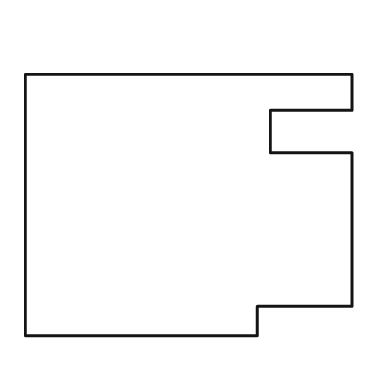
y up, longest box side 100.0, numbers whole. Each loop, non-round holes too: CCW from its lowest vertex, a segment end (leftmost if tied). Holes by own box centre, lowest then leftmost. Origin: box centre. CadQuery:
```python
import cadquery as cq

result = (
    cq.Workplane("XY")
    .moveTo(-50.0, -40.0)
    .lineTo(21.0, -40.0)
    .lineTo(21.0, -31.0)
    .lineTo(50.0, -31.0)
    .lineTo(50.0, 16.0)
    .lineTo(25.0, 16.0)
    .lineTo(25.0, 29.0)
    .lineTo(50.0, 29.0)
    .lineTo(50.0, 40.0)
    .lineTo(-50.0, 40.0)
    .close()
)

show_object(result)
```